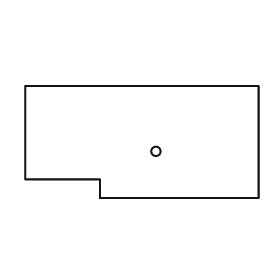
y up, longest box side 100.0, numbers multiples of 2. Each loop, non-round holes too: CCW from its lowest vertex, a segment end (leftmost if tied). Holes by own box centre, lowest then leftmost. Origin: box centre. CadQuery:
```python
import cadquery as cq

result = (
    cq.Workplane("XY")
    .moveTo(-18.0, -24.0)
    .lineTo(50.0, -24.0)
    .lineTo(50.0, 24.0)
    .lineTo(-50.0, 24.0)
    .lineTo(-50.0, -16.0)
    .lineTo(-18.0, -16.0)
    .close()
    .moveTo(6.0, -4.0)
    .circle(2.0)
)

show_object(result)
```